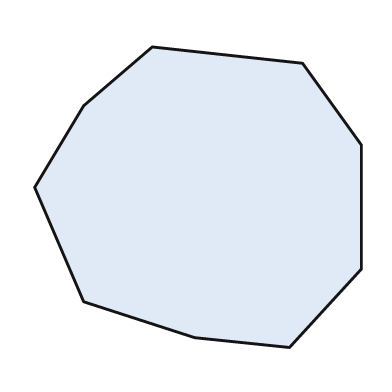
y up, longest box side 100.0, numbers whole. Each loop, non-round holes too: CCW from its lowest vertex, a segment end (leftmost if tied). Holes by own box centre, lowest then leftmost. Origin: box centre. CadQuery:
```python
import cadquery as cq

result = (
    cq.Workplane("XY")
    .moveTo(28.0, -46.0)
    .lineTo(50.0, -22.0)
    .lineTo(50.0, 16.0)
    .lineTo(32.0, 41.0)
    .lineTo(-14.0, 46.0)
    .lineTo(-35.0, 28.0)
    .lineTo(-50.0, 3.0)
    .lineTo(-35.0, -32.0)
    .lineTo(-1.0, -43.0)
    .close()
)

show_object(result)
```